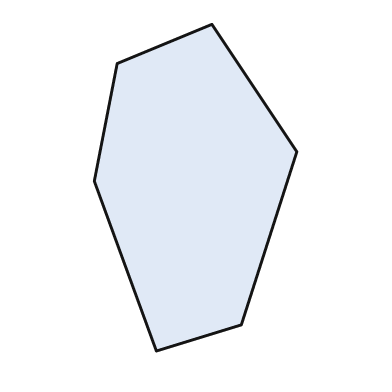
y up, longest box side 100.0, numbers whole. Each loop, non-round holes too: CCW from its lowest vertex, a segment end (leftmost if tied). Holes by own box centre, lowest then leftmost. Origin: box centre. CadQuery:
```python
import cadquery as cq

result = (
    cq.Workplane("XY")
    .moveTo(-12.0, -50.0)
    .lineTo(14.0, -42.0)
    .lineTo(31.0, 11.0)
    .lineTo(5.0, 50.0)
    .lineTo(-24.0, 38.0)
    .lineTo(-31.0, 2.0)
    .close()
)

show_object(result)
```